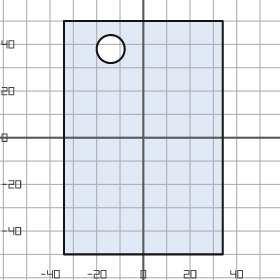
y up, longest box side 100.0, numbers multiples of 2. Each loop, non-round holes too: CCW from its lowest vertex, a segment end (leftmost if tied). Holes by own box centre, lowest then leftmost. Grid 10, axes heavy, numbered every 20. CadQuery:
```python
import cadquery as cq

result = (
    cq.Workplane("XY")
    .moveTo(-34.0, -50.0)
    .lineTo(34.0, -50.0)
    .lineTo(34.0, 50.0)
    .lineTo(-34.0, 50.0)
    .close()
    .moveTo(-14.0, 38.0)
    .circle(6.0)
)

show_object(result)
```